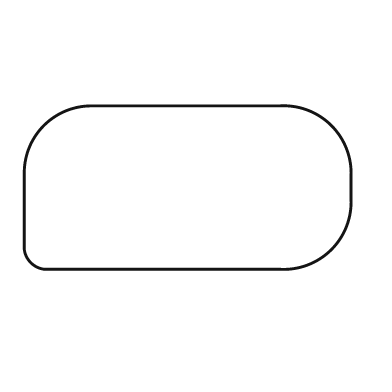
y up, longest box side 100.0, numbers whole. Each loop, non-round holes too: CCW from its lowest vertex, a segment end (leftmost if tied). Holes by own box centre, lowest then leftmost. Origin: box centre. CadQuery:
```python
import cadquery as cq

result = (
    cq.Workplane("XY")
    .moveTo(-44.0, -25.0)
    .lineTo(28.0, -25.0)
    .threePointArc((44.0, -19.0), (50.0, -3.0))
    .lineTo(50.0, 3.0)
    .threePointArc((44.0, 19.0), (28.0, 25.0))
    .lineTo(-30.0, 25.0)
    .threePointArc((-44.0, 19.0), (-50.0, 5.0))
    .lineTo(-50.0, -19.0)
    .threePointArc((-48.0, -23.0), (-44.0, -25.0))
    .close()
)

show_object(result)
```